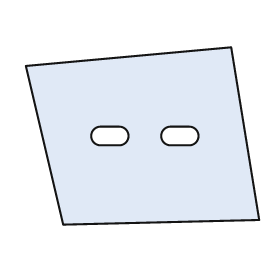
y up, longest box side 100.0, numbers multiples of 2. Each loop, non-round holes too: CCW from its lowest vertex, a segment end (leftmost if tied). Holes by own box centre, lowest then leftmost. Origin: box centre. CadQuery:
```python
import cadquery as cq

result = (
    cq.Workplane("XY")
    .moveTo(-34.0, -38.0)
    .lineTo(50.0, -36.0)
    .lineTo(38.0, 38.0)
    .lineTo(-50.0, 30.0)
    .close()
    .moveTo(-18.0, -4.0)
    .lineTo(-10.0, -4.0)
    .threePointArc((-6.0, 0.0), (-10.0, 4.0))
    .lineTo(-18.0, 4.0)
    .threePointArc((-22.0, 0.0), (-18.0, -4.0))
    .close()
    .moveTo(12.0, -4.0)
    .lineTo(20.0, -4.0)
    .threePointArc((24.0, 0.0), (20.0, 4.0))
    .lineTo(12.0, 4.0)
    .threePointArc((8.0, 0.0), (12.0, -4.0))
    .close()
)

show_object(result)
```